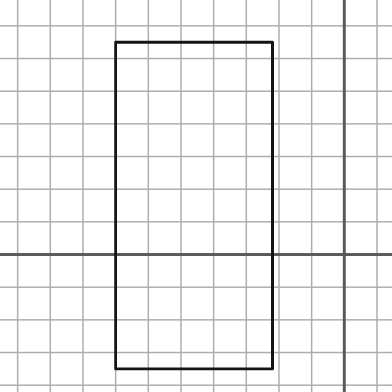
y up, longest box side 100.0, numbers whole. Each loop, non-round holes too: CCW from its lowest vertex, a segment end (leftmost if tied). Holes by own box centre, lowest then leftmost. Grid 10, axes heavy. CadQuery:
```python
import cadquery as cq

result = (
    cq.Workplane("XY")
    .moveTo(-70.0, -35.0)
    .lineTo(-22.0, -35.0)
    .lineTo(-22.0, 65.0)
    .lineTo(-70.0, 65.0)
    .close()
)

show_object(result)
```